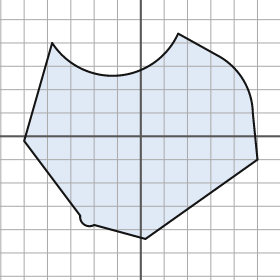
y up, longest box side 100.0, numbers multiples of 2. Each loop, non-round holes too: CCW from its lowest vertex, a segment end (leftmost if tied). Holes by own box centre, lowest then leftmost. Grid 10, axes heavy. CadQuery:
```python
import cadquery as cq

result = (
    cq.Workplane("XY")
    .moveTo(2.0, -44.0)
    .lineTo(50.0, -10.0)
    .lineTo(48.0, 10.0)
    .threePointArc((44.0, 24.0), (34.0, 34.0))
    .lineTo(16.0, 44.0)
    .threePointArc((-10.0, 26.0), (-38.0, 40.0))
    .lineTo(-50.0, -2.0)
    .lineTo(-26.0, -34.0)
    .threePointArc((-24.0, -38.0), (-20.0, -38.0))
    .close()
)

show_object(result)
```